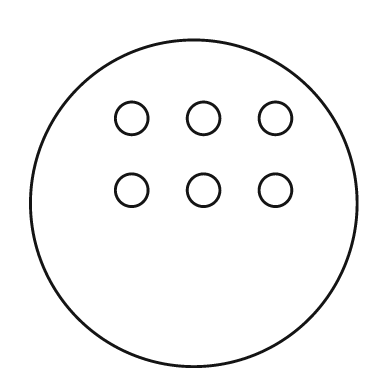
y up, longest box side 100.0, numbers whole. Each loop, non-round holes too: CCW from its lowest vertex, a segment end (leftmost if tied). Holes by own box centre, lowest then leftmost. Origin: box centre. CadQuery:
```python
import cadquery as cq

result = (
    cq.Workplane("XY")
    .moveTo(0.0, 0.0)
    .circle(50.0)
    .moveTo(-19.0, 4.0)
    .circle(5.0)
    .moveTo(3.0, 4.0)
    .circle(5.0)
    .moveTo(25.0, 4.0)
    .circle(5.0)
    .moveTo(-19.0, 26.0)
    .circle(5.0)
    .moveTo(3.0, 26.0)
    .circle(5.0)
    .moveTo(25.0, 26.0)
    .circle(5.0)
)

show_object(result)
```